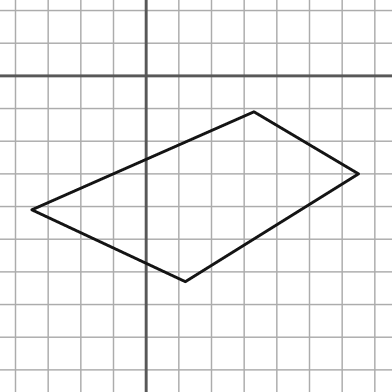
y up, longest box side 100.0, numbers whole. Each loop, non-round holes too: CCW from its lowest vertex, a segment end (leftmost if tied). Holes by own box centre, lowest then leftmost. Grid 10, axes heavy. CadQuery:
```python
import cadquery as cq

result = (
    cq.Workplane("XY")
    .moveTo(12.0, -63.0)
    .lineTo(65.0, -30.0)
    .lineTo(33.0, -11.0)
    .lineTo(-35.0, -41.0)
    .close()
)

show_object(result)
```